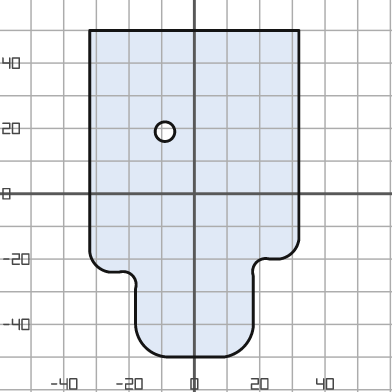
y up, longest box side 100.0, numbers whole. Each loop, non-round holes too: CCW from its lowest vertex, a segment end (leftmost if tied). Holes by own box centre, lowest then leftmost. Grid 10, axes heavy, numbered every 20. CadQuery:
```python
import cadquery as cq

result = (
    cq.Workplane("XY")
    .moveTo(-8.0, -50.0)
    .lineTo(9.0, -50.0)
    .threePointArc((15.0, -47.0), (18.0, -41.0))
    .lineTo(18.0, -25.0)
    .threePointArc((19.0, -21.0), (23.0, -20.0))
    .lineTo(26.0, -20.0)
    .threePointArc((30.0, -18.0), (32.0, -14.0))
    .lineTo(32.0, 50.0)
    .lineTo(-32.0, 50.0)
    .lineTo(-32.0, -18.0)
    .threePointArc((-30.0, -22.0), (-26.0, -24.0))
    .lineTo(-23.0, -24.0)
    .threePointArc((-19.0, -25.0), (-18.0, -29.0))
    .lineTo(-18.0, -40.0)
    .threePointArc((-15.0, -47.0), (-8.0, -50.0))
    .close()
    .moveTo(-9.0, 19.0)
    .circle(3.0)
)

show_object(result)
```